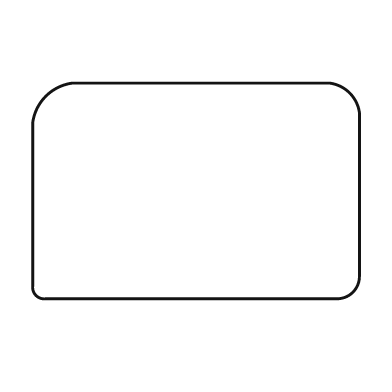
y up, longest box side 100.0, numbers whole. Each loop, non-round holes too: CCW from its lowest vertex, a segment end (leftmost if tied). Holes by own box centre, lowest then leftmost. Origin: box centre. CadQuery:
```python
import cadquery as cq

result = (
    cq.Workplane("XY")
    .moveTo(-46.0, -33.0)
    .lineTo(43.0, -33.0)
    .threePointArc((48.0, -31.0), (50.0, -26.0))
    .lineTo(50.0, 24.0)
    .threePointArc((47.0, 30.0), (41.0, 33.0))
    .lineTo(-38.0, 33.0)
    .threePointArc((-46.0, 29.0), (-50.0, 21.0))
    .lineTo(-50.0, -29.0)
    .threePointArc((-49.0, -32.0), (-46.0, -33.0))
    .close()
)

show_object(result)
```